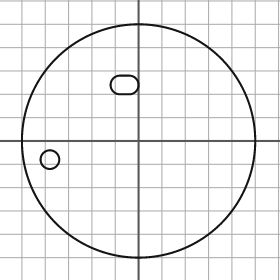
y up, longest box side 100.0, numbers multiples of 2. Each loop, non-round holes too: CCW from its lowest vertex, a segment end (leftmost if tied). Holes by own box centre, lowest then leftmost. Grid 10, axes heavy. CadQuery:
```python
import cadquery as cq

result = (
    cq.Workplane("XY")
    .moveTo(0.0, 0.0)
    .circle(50.0)
    .moveTo(-38.0, -8.0)
    .circle(4.0)
    .moveTo(-8.0, 20.0)
    .lineTo(-4.0, 20.0)
    .threePointArc((0.0, 24.0), (-4.0, 28.0))
    .lineTo(-8.0, 28.0)
    .threePointArc((-12.0, 24.0), (-8.0, 20.0))
    .close()
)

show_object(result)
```